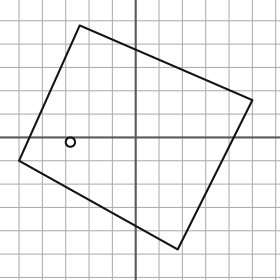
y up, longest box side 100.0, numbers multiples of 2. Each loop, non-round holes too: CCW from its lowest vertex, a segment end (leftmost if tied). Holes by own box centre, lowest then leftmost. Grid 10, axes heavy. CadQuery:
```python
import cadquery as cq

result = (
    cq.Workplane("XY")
    .moveTo(18.0, -48.0)
    .lineTo(50.0, 16.0)
    .lineTo(-24.0, 48.0)
    .lineTo(-50.0, -10.0)
    .close()
    .moveTo(-28.0, -2.0)
    .circle(2.0)
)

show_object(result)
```